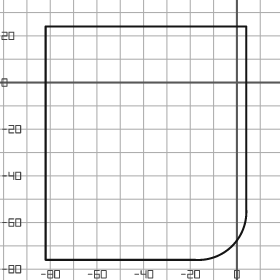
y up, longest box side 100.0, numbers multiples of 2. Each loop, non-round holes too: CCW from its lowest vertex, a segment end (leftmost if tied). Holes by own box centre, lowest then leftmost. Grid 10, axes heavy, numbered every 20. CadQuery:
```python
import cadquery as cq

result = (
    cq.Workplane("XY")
    .moveTo(-82.0, -76.0)
    .lineTo(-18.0, -76.0)
    .threePointArc((-2.0, -70.0), (4.0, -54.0))
    .lineTo(4.0, 24.0)
    .lineTo(-82.0, 24.0)
    .close()
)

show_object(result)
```